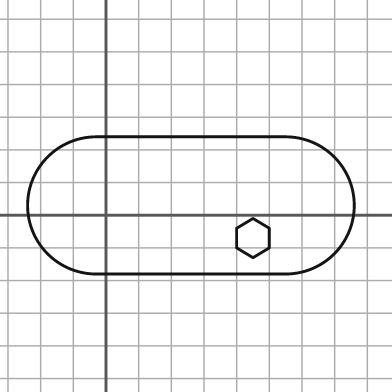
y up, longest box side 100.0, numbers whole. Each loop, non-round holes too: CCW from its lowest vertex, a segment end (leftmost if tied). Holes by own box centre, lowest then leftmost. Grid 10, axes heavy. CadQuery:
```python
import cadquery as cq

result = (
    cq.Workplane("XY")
    .moveTo(-3.0, -18.0)
    .lineTo(55.0, -18.0)
    .threePointArc((76.0, 3.0), (55.0, 24.0))
    .lineTo(-3.0, 24.0)
    .threePointArc((-24.0, 3.0), (-3.0, -18.0))
    .close()
    .moveTo(45.0, -13.0)
    .lineTo(50.0, -10.0)
    .lineTo(50.0, -4.0)
    .lineTo(45.0, -1.0)
    .lineTo(40.0, -4.0)
    .lineTo(40.0, -10.0)
    .close()
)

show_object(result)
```